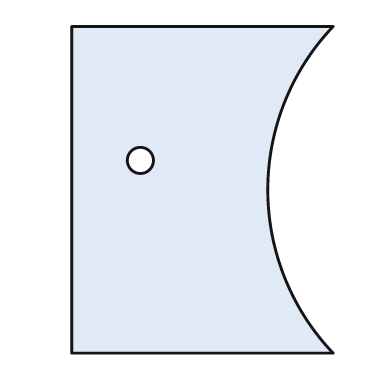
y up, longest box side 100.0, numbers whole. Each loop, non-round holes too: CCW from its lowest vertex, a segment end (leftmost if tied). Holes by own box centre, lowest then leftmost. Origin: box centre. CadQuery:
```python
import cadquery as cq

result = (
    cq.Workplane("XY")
    .moveTo(-40.0, -50.0)
    .lineTo(40.0, -50.0)
    .threePointArc((20.0, 0.0), (40.0, 50.0))
    .lineTo(-40.0, 50.0)
    .close()
    .moveTo(-19.0, 9.0)
    .circle(4.0)
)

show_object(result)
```